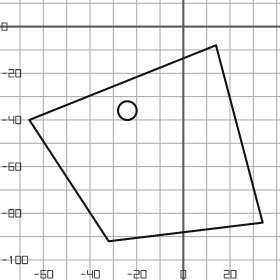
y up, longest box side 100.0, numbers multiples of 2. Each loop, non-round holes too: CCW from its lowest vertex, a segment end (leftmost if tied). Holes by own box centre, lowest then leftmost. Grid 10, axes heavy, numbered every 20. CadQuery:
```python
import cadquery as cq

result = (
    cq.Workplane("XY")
    .moveTo(-32.0, -92.0)
    .lineTo(34.0, -84.0)
    .lineTo(14.0, -8.0)
    .lineTo(-66.0, -40.0)
    .close()
    .moveTo(-24.0, -36.0)
    .circle(4.0)
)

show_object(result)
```